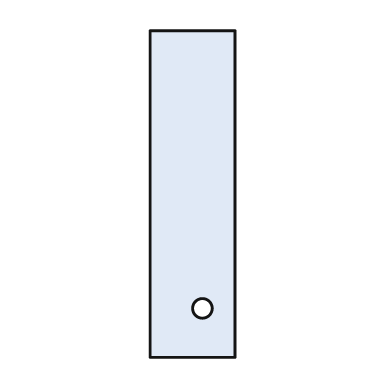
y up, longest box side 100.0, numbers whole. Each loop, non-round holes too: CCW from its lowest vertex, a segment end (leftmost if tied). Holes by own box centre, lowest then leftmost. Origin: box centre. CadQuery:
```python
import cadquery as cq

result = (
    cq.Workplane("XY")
    .moveTo(-13.0, -50.0)
    .lineTo(13.0, -50.0)
    .lineTo(13.0, 50.0)
    .lineTo(-13.0, 50.0)
    .close()
    .moveTo(3.0, -35.0)
    .circle(3.0)
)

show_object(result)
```